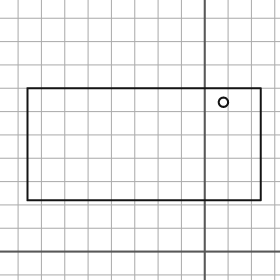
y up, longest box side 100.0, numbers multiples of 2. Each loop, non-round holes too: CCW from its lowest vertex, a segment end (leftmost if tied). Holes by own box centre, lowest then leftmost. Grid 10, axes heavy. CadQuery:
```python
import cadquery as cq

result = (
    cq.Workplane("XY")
    .moveTo(-76.0, 22.0)
    .lineTo(24.0, 22.0)
    .lineTo(24.0, 70.0)
    .lineTo(-76.0, 70.0)
    .close()
    .moveTo(8.0, 64.0)
    .circle(2.0)
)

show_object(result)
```